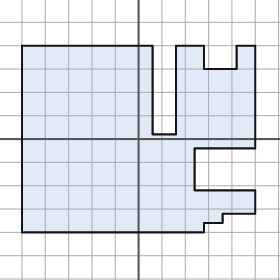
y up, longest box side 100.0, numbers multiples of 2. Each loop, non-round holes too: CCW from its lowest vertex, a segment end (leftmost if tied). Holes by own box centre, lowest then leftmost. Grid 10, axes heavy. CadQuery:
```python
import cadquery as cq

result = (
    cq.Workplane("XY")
    .moveTo(-50.0, -40.0)
    .lineTo(28.0, -40.0)
    .lineTo(28.0, -36.0)
    .lineTo(36.0, -36.0)
    .lineTo(36.0, -32.0)
    .lineTo(50.0, -32.0)
    .lineTo(50.0, -22.0)
    .lineTo(24.0, -22.0)
    .lineTo(24.0, -4.0)
    .lineTo(50.0, -4.0)
    .lineTo(50.0, 40.0)
    .lineTo(42.0, 40.0)
    .lineTo(42.0, 30.0)
    .lineTo(28.0, 30.0)
    .lineTo(28.0, 40.0)
    .lineTo(16.0, 40.0)
    .lineTo(16.0, 2.0)
    .lineTo(6.0, 2.0)
    .lineTo(6.0, 40.0)
    .lineTo(-50.0, 40.0)
    .close()
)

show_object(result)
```